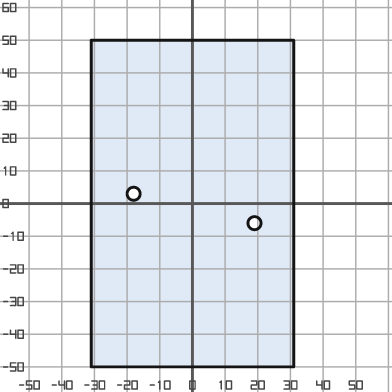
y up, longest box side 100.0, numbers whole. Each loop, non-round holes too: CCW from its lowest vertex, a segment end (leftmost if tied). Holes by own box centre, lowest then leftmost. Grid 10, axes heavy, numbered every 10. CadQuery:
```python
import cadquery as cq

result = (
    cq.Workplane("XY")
    .moveTo(-31.0, -50.0)
    .lineTo(31.0, -50.0)
    .lineTo(31.0, 50.0)
    .lineTo(-31.0, 50.0)
    .close()
    .moveTo(19.0, -6.0)
    .circle(2.0)
    .moveTo(-18.0, 3.0)
    .circle(2.0)
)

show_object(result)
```